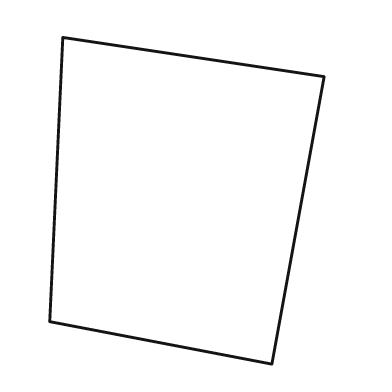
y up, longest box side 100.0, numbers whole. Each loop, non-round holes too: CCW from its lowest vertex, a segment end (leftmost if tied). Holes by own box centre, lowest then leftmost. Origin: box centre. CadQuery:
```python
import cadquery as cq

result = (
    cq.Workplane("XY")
    .moveTo(26.0, -50.0)
    .lineTo(42.0, 38.0)
    .lineTo(-38.0, 50.0)
    .lineTo(-42.0, -37.0)
    .close()
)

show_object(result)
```